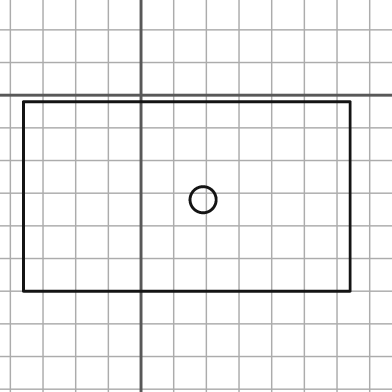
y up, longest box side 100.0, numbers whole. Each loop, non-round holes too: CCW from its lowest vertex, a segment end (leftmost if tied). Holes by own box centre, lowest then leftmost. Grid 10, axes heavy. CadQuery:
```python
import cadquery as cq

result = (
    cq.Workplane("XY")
    .moveTo(-36.0, -60.0)
    .lineTo(64.0, -60.0)
    .lineTo(64.0, -2.0)
    .lineTo(-36.0, -2.0)
    .close()
    .moveTo(19.0, -32.0)
    .circle(4.0)
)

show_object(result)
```